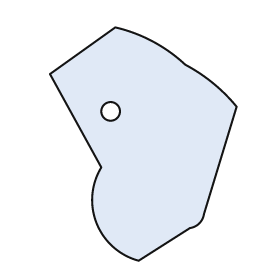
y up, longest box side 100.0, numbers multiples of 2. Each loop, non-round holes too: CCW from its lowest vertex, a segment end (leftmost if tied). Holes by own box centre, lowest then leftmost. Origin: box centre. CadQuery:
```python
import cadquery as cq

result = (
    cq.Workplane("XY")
    .moveTo(-2.0, -50.0)
    .lineTo(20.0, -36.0)
    .threePointArc((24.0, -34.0), (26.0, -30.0))
    .lineTo(40.0, 16.0)
    .threePointArc((30.0, 26.0), (18.0, 34.0))
    .threePointArc((4.0, 44.0), (-12.0, 50.0))
    .lineTo(-40.0, 30.0)
    .lineTo(-18.0, -10.0)
    .threePointArc((-20.0, -34.0), (-2.0, -50.0))
    .close()
    .moveTo(-14.0, 14.0)
    .circle(4.0)
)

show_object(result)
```